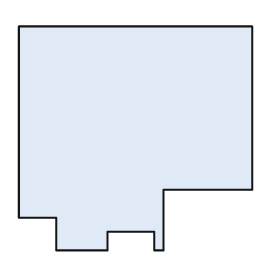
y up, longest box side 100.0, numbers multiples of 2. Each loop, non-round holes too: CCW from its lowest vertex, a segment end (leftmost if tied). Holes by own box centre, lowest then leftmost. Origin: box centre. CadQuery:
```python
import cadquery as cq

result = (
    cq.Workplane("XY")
    .moveTo(-34.0, -48.0)
    .lineTo(-12.0, -48.0)
    .lineTo(-12.0, -40.0)
    .lineTo(8.0, -40.0)
    .lineTo(8.0, -48.0)
    .lineTo(12.0, -48.0)
    .lineTo(12.0, -22.0)
    .lineTo(50.0, -22.0)
    .lineTo(50.0, 48.0)
    .lineTo(-50.0, 48.0)
    .lineTo(-50.0, -34.0)
    .lineTo(-34.0, -34.0)
    .close()
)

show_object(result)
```